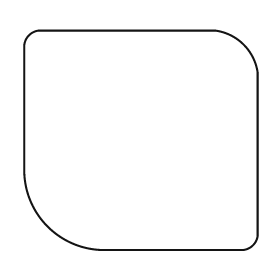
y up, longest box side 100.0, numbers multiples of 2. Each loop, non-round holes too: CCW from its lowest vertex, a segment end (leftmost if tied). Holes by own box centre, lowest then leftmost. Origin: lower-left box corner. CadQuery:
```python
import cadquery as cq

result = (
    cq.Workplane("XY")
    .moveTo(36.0, 0.0)
    .lineTo(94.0, 0.0)
    .threePointArc((98.0, 2.0), (100.0, 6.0))
    .lineTo(100.0, 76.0)
    .threePointArc((94.0, 88.0), (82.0, 94.0))
    .lineTo(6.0, 94.0)
    .threePointArc((2.0, 92.0), (0.0, 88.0))
    .lineTo(0.0, 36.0)
    .threePointArc((10.0, 10.0), (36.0, 0.0))
    .close()
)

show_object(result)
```